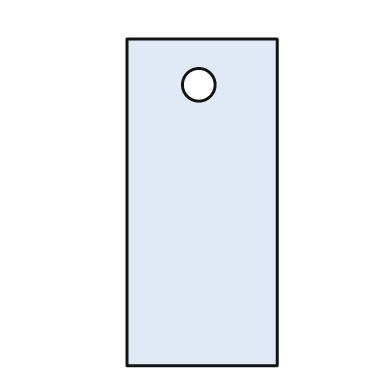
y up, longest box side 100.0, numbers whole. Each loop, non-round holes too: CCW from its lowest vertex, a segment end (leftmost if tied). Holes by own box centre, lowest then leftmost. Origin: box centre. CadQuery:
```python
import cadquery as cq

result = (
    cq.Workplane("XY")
    .moveTo(-23.0, -50.0)
    .lineTo(23.0, -50.0)
    .lineTo(23.0, 50.0)
    .lineTo(-23.0, 50.0)
    .close()
    .moveTo(-1.0, 36.0)
    .circle(5.0)
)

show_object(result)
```